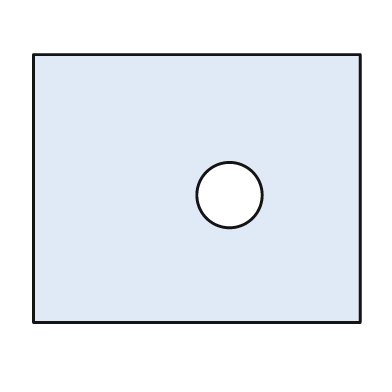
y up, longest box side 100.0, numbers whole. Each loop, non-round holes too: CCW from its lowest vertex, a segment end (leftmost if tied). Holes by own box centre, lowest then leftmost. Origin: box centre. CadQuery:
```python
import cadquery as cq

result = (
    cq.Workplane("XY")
    .moveTo(-50.0, -41.0)
    .lineTo(50.0, -41.0)
    .lineTo(50.0, 41.0)
    .lineTo(-50.0, 41.0)
    .close()
    .moveTo(10.0, -2.0)
    .circle(10.0)
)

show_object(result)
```